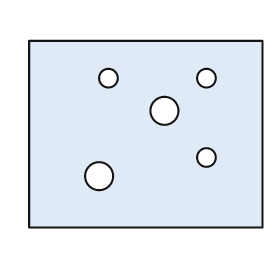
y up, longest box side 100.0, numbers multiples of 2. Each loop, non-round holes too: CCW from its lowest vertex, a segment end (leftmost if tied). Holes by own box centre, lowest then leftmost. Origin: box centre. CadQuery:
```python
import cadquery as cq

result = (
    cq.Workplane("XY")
    .moveTo(-50.0, -40.0)
    .lineTo(50.0, -40.0)
    .lineTo(50.0, 40.0)
    .lineTo(-50.0, 40.0)
    .close()
    .moveTo(-20.0, -18.0)
    .circle(6.0)
    .moveTo(26.0, -10.0)
    .circle(4.0)
    .moveTo(8.0, 10.0)
    .circle(6.0)
    .moveTo(-16.0, 24.0)
    .circle(4.0)
    .moveTo(26.0, 24.0)
    .circle(4.0)
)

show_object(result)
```